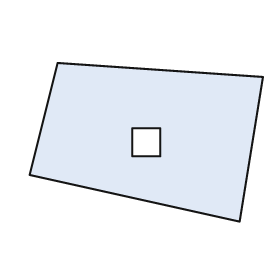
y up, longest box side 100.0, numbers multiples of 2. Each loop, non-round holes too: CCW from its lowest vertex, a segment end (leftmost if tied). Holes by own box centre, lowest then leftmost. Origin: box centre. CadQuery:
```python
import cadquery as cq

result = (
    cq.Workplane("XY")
    .moveTo(40.0, -34.0)
    .lineTo(50.0, 28.0)
    .lineTo(-38.0, 34.0)
    .lineTo(-50.0, -14.0)
    .close()
    .moveTo(-6.0, -6.0)
    .lineTo(6.0, -6.0)
    .lineTo(6.0, 6.0)
    .lineTo(-6.0, 6.0)
    .close()
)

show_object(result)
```